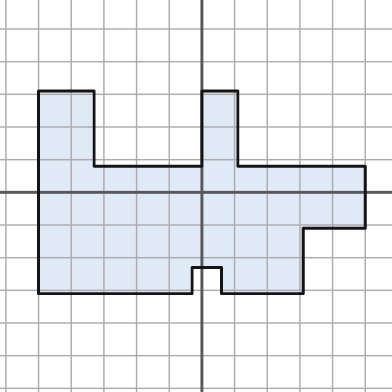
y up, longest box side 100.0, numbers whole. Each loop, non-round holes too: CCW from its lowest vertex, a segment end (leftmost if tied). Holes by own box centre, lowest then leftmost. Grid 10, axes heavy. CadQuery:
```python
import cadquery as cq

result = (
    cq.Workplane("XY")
    .moveTo(-50.0, -31.0)
    .lineTo(-3.0, -31.0)
    .lineTo(-3.0, -23.0)
    .lineTo(6.0, -23.0)
    .lineTo(6.0, -31.0)
    .lineTo(31.0, -31.0)
    .lineTo(31.0, -11.0)
    .lineTo(50.0, -11.0)
    .lineTo(50.0, 8.0)
    .lineTo(11.0, 8.0)
    .lineTo(11.0, 31.0)
    .lineTo(0.0, 31.0)
    .lineTo(0.0, 8.0)
    .lineTo(-33.0, 8.0)
    .lineTo(-33.0, 31.0)
    .lineTo(-50.0, 31.0)
    .close()
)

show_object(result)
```